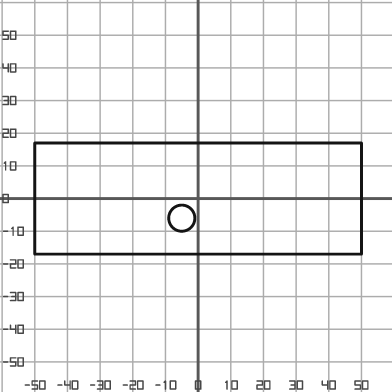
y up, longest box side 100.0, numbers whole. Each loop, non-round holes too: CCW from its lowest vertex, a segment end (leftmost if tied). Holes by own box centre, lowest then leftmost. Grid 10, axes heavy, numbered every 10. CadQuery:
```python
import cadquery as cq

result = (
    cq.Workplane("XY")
    .moveTo(-50.0, -17.0)
    .lineTo(50.0, -17.0)
    .lineTo(50.0, 17.0)
    .lineTo(-50.0, 17.0)
    .close()
    .moveTo(-5.0, -6.0)
    .circle(4.0)
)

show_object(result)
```